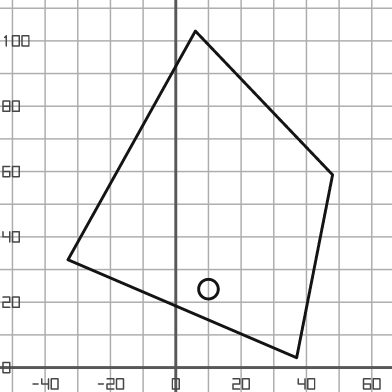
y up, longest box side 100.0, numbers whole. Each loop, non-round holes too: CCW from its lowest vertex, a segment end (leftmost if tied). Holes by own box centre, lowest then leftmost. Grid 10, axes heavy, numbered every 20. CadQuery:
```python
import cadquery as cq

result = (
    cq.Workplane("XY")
    .moveTo(37.0, 3.0)
    .lineTo(48.0, 59.0)
    .lineTo(6.0, 103.0)
    .lineTo(-33.0, 33.0)
    .close()
    .moveTo(10.0, 24.0)
    .circle(3.0)
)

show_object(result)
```